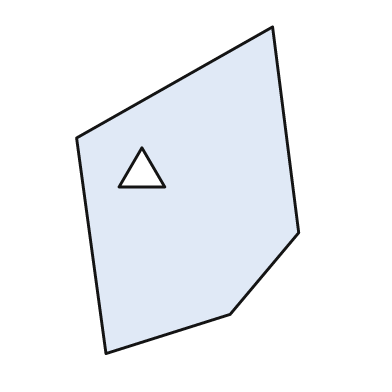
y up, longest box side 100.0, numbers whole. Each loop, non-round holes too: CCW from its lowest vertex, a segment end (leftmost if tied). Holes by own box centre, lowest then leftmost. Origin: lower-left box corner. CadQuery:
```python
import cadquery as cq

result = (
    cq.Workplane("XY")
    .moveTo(9.0, 0.0)
    .lineTo(47.0, 12.0)
    .lineTo(68.0, 37.0)
    .lineTo(60.0, 100.0)
    .lineTo(0.0, 66.0)
    .close()
    .moveTo(13.0, 51.0)
    .lineTo(27.0, 51.0)
    .lineTo(20.0, 63.0)
    .close()
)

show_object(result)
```